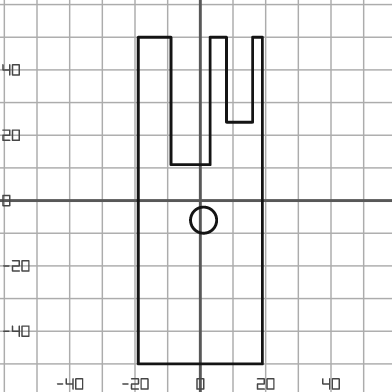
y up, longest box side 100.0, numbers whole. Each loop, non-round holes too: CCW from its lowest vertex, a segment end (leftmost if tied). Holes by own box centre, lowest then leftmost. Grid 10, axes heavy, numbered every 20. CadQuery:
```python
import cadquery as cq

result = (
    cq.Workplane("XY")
    .moveTo(-19.0, -50.0)
    .lineTo(19.0, -50.0)
    .lineTo(19.0, 50.0)
    .lineTo(16.0, 50.0)
    .lineTo(16.0, 24.0)
    .lineTo(8.0, 24.0)
    .lineTo(8.0, 50.0)
    .lineTo(3.0, 50.0)
    .lineTo(3.0, 11.0)
    .lineTo(-9.0, 11.0)
    .lineTo(-9.0, 50.0)
    .lineTo(-19.0, 50.0)
    .close()
    .moveTo(1.0, -6.0)
    .circle(4.0)
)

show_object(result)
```